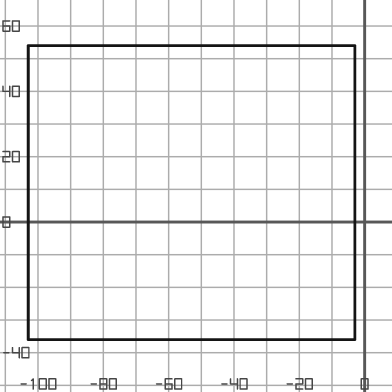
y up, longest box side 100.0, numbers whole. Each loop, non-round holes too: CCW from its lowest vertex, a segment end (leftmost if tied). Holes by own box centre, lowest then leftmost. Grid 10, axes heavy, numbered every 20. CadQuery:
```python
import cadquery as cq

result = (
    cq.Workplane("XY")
    .moveTo(-103.0, -36.0)
    .lineTo(-3.0, -36.0)
    .lineTo(-3.0, 54.0)
    .lineTo(-103.0, 54.0)
    .close()
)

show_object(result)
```